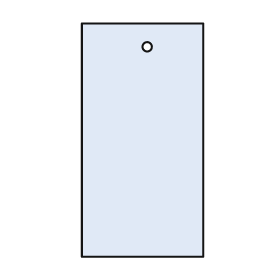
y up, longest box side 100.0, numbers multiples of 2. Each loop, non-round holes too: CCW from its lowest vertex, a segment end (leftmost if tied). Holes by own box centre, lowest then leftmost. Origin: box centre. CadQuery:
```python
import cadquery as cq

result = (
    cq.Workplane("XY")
    .moveTo(-26.0, -50.0)
    .lineTo(26.0, -50.0)
    .lineTo(26.0, 50.0)
    .lineTo(-26.0, 50.0)
    .close()
    .moveTo(2.0, 40.0)
    .circle(2.0)
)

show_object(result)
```